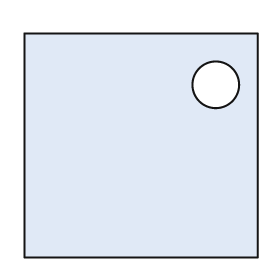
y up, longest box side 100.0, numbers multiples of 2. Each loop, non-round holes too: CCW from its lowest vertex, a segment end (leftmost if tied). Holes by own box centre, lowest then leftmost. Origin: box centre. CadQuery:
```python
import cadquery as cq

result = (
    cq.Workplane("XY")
    .moveTo(-50.0, -48.0)
    .lineTo(50.0, -48.0)
    .lineTo(50.0, 48.0)
    .lineTo(-50.0, 48.0)
    .close()
    .moveTo(32.0, 26.0)
    .circle(10.0)
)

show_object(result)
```